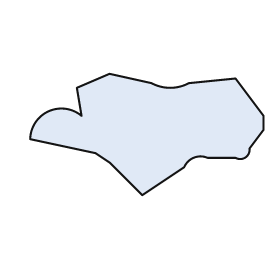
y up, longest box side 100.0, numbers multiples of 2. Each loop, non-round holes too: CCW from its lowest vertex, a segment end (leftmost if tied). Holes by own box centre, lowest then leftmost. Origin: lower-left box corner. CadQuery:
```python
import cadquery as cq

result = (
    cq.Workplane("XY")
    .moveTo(48.0, 0.0)
    .lineTo(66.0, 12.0)
    .threePointArc((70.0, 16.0), (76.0, 16.0))
    .lineTo(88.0, 16.0)
    .threePointArc((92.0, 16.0), (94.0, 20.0))
    .lineTo(100.0, 28.0)
    .lineTo(100.0, 34.0)
    .lineTo(88.0, 50.0)
    .lineTo(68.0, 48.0)
    .threePointArc((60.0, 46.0), (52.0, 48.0))
    .lineTo(34.0, 52.0)
    .lineTo(20.0, 46.0)
    .lineTo(22.0, 34.0)
    .threePointArc((8.0, 36.0), (0.0, 24.0))
    .lineTo(28.0, 18.0)
    .lineTo(34.0, 14.0)
    .close()
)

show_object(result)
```